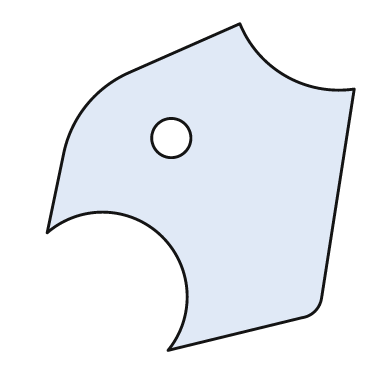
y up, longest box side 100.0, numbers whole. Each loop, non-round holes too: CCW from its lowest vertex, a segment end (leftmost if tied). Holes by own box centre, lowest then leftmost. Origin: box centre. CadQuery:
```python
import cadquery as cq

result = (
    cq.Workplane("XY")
    .moveTo(-10.0, -50.0)
    .lineTo(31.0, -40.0)
    .threePointArc((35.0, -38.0), (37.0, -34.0))
    .lineTo(47.0, 30.0)
    .threePointArc((26.0, 34.0), (12.0, 50.0))
    .lineTo(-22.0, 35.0)
    .threePointArc((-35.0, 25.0), (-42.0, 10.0))
    .lineTo(-47.0, -14.0)
    .threePointArc((-12.0, -15.0), (-10.0, -50.0))
    .close()
    .moveTo(-9.0, 15.0)
    .circle(6.0)
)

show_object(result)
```